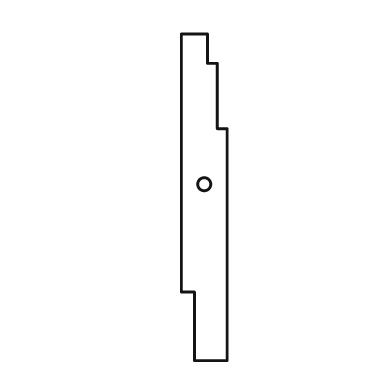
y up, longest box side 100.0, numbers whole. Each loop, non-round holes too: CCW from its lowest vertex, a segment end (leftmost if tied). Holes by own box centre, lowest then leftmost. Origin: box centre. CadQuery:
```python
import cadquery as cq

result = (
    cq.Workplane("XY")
    .moveTo(-3.0, -50.0)
    .lineTo(7.0, -50.0)
    .lineTo(7.0, 21.0)
    .lineTo(4.0, 21.0)
    .lineTo(4.0, 41.0)
    .lineTo(1.0, 41.0)
    .lineTo(1.0, 50.0)
    .lineTo(-7.0, 50.0)
    .lineTo(-7.0, -29.0)
    .lineTo(-3.0, -29.0)
    .close()
    .moveTo(0.0, 4.0)
    .circle(2.0)
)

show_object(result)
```